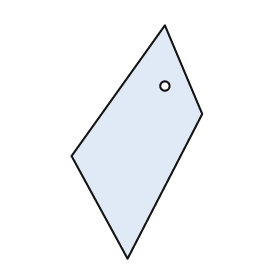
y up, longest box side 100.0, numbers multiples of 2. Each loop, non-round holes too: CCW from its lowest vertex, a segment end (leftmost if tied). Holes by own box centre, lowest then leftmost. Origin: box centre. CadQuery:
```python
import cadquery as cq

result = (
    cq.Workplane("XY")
    .moveTo(-4.0, -50.0)
    .lineTo(28.0, 12.0)
    .lineTo(12.0, 50.0)
    .lineTo(-28.0, -6.0)
    .close()
    .moveTo(12.0, 24.0)
    .circle(2.0)
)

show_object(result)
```